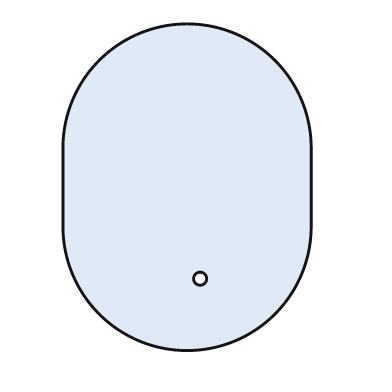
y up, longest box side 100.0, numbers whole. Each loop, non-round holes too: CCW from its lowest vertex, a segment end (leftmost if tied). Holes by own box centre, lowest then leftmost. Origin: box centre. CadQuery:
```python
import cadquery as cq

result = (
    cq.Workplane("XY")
    .moveTo(-38.0, -12.0)
    .threePointArc((0.0, -50.0), (38.0, -12.0))
    .lineTo(38.0, 12.0)
    .threePointArc((0.0, 50.0), (-38.0, 12.0))
    .close()
    .moveTo(4.0, -28.0)
    .circle(2.0)
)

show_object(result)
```